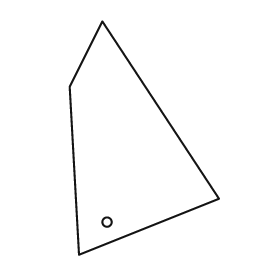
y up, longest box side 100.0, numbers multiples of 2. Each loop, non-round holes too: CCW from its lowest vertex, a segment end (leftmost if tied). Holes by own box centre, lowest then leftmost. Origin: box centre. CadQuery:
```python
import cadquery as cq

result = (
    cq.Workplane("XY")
    .moveTo(-28.0, -50.0)
    .lineTo(32.0, -26.0)
    .lineTo(-18.0, 50.0)
    .lineTo(-32.0, 22.0)
    .close()
    .moveTo(-16.0, -36.0)
    .circle(2.0)
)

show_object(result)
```